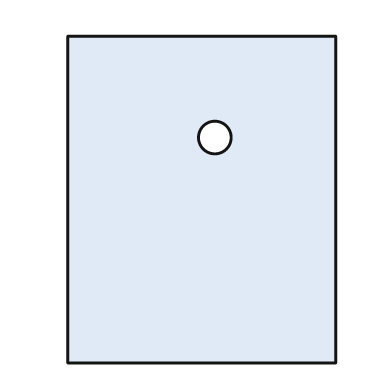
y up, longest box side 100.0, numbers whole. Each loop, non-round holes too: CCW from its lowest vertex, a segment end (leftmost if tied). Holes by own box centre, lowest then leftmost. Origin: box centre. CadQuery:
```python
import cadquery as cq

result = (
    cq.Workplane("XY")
    .moveTo(-41.0, -50.0)
    .lineTo(41.0, -50.0)
    .lineTo(41.0, 50.0)
    .lineTo(-41.0, 50.0)
    .close()
    .moveTo(4.0, 19.0)
    .circle(5.0)
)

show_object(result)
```